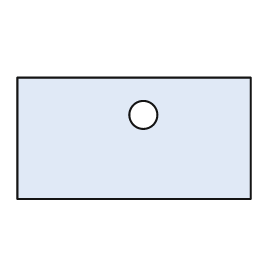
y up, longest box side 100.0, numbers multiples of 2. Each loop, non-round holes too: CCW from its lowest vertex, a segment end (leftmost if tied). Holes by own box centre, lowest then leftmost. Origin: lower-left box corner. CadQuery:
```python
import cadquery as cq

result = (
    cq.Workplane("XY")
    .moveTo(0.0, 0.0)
    .lineTo(100.0, 0.0)
    .lineTo(100.0, 52.0)
    .lineTo(0.0, 52.0)
    .close()
    .moveTo(54.0, 36.0)
    .circle(6.0)
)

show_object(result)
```